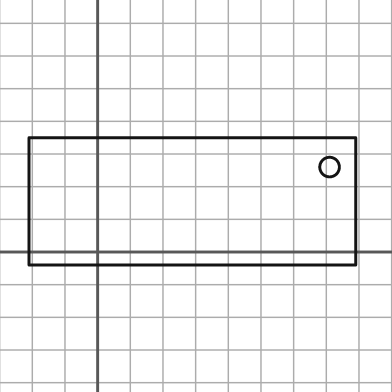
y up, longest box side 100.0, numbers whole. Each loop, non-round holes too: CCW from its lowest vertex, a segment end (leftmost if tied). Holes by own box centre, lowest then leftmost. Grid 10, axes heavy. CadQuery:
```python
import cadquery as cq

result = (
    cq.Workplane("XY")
    .moveTo(-21.0, -4.0)
    .lineTo(79.0, -4.0)
    .lineTo(79.0, 35.0)
    .lineTo(-21.0, 35.0)
    .close()
    .moveTo(71.0, 26.0)
    .circle(3.0)
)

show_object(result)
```